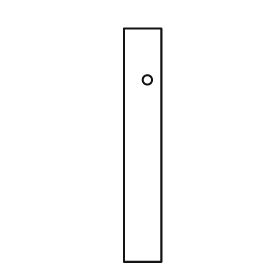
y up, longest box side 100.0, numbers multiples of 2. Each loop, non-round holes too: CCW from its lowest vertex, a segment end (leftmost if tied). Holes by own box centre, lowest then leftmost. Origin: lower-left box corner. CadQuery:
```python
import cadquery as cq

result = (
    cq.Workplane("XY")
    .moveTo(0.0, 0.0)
    .lineTo(16.0, 0.0)
    .lineTo(16.0, 100.0)
    .lineTo(0.0, 100.0)
    .close()
    .moveTo(10.0, 78.0)
    .circle(2.0)
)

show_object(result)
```